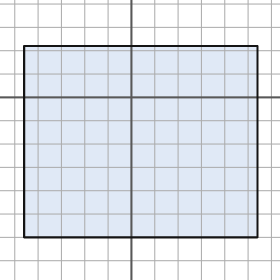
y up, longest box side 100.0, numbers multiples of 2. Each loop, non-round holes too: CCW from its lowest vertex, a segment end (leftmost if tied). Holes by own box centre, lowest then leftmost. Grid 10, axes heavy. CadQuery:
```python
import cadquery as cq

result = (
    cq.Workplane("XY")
    .moveTo(-46.0, -60.0)
    .lineTo(54.0, -60.0)
    .lineTo(54.0, 22.0)
    .lineTo(-46.0, 22.0)
    .close()
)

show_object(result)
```